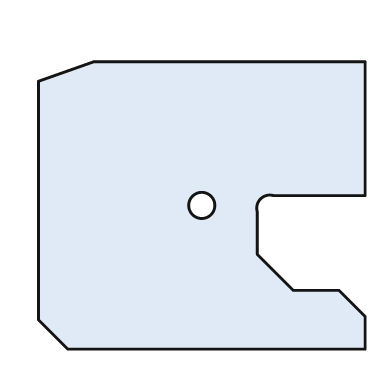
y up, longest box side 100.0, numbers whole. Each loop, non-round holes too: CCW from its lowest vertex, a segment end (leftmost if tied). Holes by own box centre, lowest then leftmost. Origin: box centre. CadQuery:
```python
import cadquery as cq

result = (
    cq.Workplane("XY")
    .moveTo(-41.0, -44.0)
    .lineTo(50.0, -44.0)
    .lineTo(50.0, -34.0)
    .lineTo(42.0, -26.0)
    .lineTo(28.0, -26.0)
    .lineTo(17.0, -15.0)
    .lineTo(17.0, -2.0)
    .threePointArc((18.0, 2.0), (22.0, 3.0))
    .lineTo(50.0, 3.0)
    .lineTo(50.0, 44.0)
    .lineTo(-33.0, 44.0)
    .lineTo(-50.0, 38.0)
    .lineTo(-50.0, -35.0)
    .close()
    .moveTo(0.0, 0.0)
    .circle(4.0)
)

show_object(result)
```